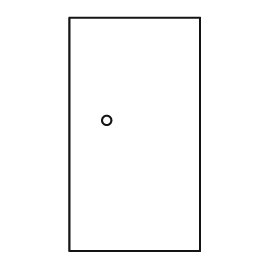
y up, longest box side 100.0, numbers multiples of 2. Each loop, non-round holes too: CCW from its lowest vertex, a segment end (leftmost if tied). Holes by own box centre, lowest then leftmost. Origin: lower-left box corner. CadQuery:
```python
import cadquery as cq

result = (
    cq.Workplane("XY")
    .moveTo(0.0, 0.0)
    .lineTo(56.0, 0.0)
    .lineTo(56.0, 100.0)
    .lineTo(0.0, 100.0)
    .close()
    .moveTo(16.0, 56.0)
    .circle(2.0)
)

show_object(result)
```